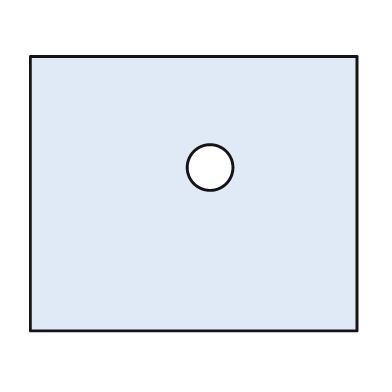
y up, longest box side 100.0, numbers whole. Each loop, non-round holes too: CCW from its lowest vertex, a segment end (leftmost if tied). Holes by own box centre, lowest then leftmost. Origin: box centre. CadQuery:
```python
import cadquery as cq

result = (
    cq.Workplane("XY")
    .moveTo(-50.0, -42.0)
    .lineTo(50.0, -42.0)
    .lineTo(50.0, 42.0)
    .lineTo(-50.0, 42.0)
    .close()
    .moveTo(5.0, 8.0)
    .circle(7.0)
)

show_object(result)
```